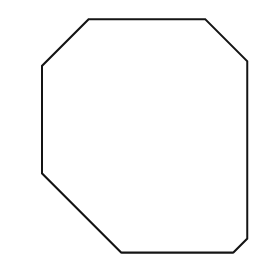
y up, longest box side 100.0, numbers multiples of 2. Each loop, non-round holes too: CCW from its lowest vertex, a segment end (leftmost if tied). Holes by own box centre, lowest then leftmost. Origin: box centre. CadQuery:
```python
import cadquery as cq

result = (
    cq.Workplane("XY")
    .moveTo(-10.0, -50.0)
    .lineTo(38.0, -50.0)
    .lineTo(44.0, -44.0)
    .lineTo(44.0, 32.0)
    .lineTo(26.0, 50.0)
    .lineTo(-24.0, 50.0)
    .lineTo(-44.0, 30.0)
    .lineTo(-44.0, -16.0)
    .close()
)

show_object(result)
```